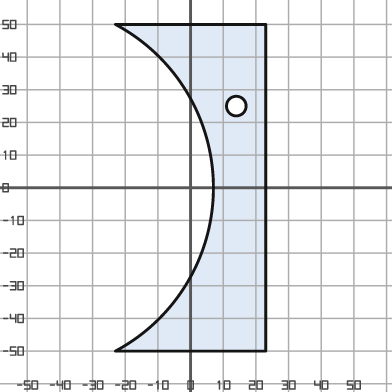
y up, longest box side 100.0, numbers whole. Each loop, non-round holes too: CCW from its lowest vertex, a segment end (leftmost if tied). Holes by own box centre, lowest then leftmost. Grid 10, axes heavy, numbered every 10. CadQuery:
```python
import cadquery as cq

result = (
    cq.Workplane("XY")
    .moveTo(-23.0, -50.0)
    .lineTo(23.0, -50.0)
    .lineTo(23.0, 50.0)
    .lineTo(-23.0, 50.0)
    .threePointArc((7.0, 0.0), (-23.0, -50.0))
    .close()
    .moveTo(14.0, 25.0)
    .circle(3.0)
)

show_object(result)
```